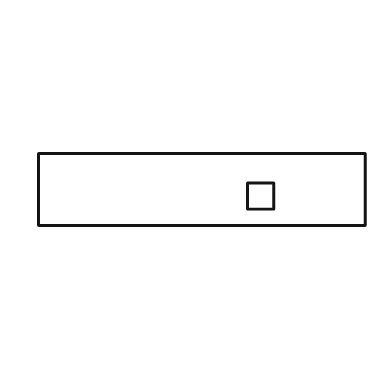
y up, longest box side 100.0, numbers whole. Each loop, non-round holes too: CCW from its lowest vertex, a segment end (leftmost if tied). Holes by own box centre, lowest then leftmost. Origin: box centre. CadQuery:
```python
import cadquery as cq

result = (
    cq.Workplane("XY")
    .moveTo(-50.0, -11.0)
    .lineTo(50.0, -11.0)
    .lineTo(50.0, 11.0)
    .lineTo(-50.0, 11.0)
    .close()
    .moveTo(14.0, -6.0)
    .lineTo(22.0, -6.0)
    .lineTo(22.0, 2.0)
    .lineTo(14.0, 2.0)
    .close()
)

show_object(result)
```